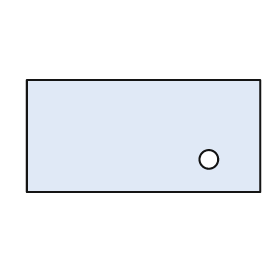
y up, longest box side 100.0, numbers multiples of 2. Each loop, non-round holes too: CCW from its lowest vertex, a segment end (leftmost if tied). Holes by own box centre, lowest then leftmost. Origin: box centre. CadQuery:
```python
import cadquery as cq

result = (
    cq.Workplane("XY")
    .moveTo(-50.0, -24.0)
    .lineTo(50.0, -24.0)
    .lineTo(50.0, 24.0)
    .lineTo(-50.0, 24.0)
    .close()
    .moveTo(28.0, -10.0)
    .circle(4.0)
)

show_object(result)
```